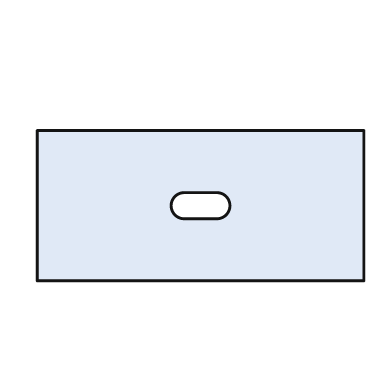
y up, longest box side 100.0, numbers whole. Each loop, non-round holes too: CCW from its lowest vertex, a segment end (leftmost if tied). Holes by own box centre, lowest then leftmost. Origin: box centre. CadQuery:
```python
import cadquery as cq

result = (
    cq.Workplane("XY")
    .moveTo(-50.0, -23.0)
    .lineTo(50.0, -23.0)
    .lineTo(50.0, 23.0)
    .lineTo(-50.0, 23.0)
    .close()
    .moveTo(-5.0, -4.0)
    .lineTo(5.0, -4.0)
    .threePointArc((9.0, 0.0), (5.0, 4.0))
    .lineTo(-5.0, 4.0)
    .threePointArc((-9.0, 0.0), (-5.0, -4.0))
    .close()
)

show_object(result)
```